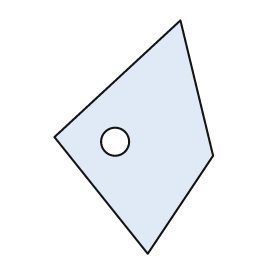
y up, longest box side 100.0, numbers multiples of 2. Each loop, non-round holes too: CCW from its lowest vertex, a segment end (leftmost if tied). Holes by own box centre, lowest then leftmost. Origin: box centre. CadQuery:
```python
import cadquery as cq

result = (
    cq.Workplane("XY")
    .moveTo(6.0, -50.0)
    .lineTo(34.0, -8.0)
    .lineTo(20.0, 50.0)
    .lineTo(-34.0, 0.0)
    .close()
    .moveTo(-8.0, -2.0)
    .circle(6.0)
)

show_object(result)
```